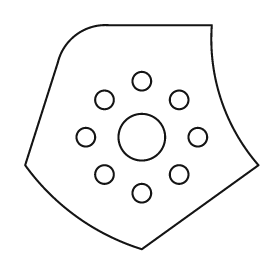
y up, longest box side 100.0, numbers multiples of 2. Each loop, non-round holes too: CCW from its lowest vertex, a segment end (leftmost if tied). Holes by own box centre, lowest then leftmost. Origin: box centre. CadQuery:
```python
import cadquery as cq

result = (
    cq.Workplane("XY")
    .moveTo(0.0, -48.0)
    .lineTo(50.0, -12.0)
    .threePointArc((34.0, 16.0), (30.0, 48.0))
    .lineTo(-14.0, 48.0)
    .threePointArc((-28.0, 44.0), (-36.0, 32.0))
    .lineTo(-50.0, -12.0)
    .threePointArc((-28.0, -34.0), (0.0, -48.0))
    .close()
    .moveTo(0.0, -24.0)
    .circle(4.0)
    .moveTo(-16.0, -16.0)
    .circle(4.0)
    .moveTo(16.0, -16.0)
    .circle(4.0)
    .moveTo(-24.0, 0.0)
    .circle(4.0)
    .moveTo(0.0, 0.0)
    .circle(10.0)
    .moveTo(24.0, 0.0)
    .circle(4.0)
    .moveTo(-16.0, 16.0)
    .circle(4.0)
    .moveTo(16.0, 16.0)
    .circle(4.0)
    .moveTo(0.0, 24.0)
    .circle(4.0)
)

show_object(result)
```